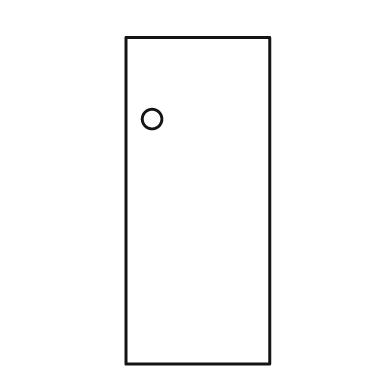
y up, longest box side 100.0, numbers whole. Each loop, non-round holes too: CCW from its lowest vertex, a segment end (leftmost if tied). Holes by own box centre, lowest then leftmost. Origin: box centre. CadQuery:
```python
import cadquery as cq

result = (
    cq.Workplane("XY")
    .moveTo(-22.0, -50.0)
    .lineTo(22.0, -50.0)
    .lineTo(22.0, 50.0)
    .lineTo(-22.0, 50.0)
    .close()
    .moveTo(-14.0, 25.0)
    .circle(3.0)
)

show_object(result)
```